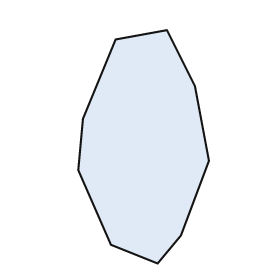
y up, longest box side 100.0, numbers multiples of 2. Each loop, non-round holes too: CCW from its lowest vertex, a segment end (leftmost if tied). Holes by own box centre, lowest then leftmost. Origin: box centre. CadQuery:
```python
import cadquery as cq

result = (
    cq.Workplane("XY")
    .moveTo(6.0, -50.0)
    .lineTo(16.0, -38.0)
    .lineTo(28.0, -6.0)
    .lineTo(22.0, 26.0)
    .lineTo(10.0, 50.0)
    .lineTo(-12.0, 46.0)
    .lineTo(-26.0, 12.0)
    .lineTo(-28.0, -10.0)
    .lineTo(-14.0, -42.0)
    .close()
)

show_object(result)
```